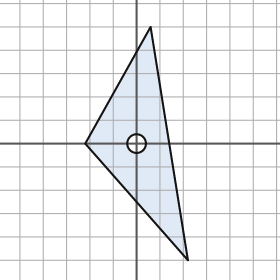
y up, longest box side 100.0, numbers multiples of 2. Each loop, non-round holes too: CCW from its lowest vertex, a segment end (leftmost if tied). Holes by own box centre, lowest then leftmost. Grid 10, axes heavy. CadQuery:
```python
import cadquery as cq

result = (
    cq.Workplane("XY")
    .moveTo(22.0, -50.0)
    .lineTo(6.0, 50.0)
    .lineTo(-22.0, 0.0)
    .close()
    .moveTo(0.0, 0.0)
    .circle(4.0)
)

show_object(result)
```